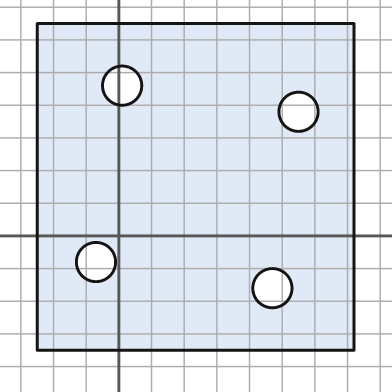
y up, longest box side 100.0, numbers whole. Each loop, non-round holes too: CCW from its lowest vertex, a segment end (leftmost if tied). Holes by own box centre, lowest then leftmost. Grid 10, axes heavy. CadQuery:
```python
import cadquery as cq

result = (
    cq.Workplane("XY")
    .moveTo(-25.0, -35.0)
    .lineTo(72.0, -35.0)
    .lineTo(72.0, 65.0)
    .lineTo(-25.0, 65.0)
    .close()
    .moveTo(47.0, -16.0)
    .circle(6.0)
    .moveTo(-7.0, -8.0)
    .circle(6.0)
    .moveTo(55.0, 38.0)
    .circle(6.0)
    .moveTo(1.0, 46.0)
    .circle(6.0)
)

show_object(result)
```